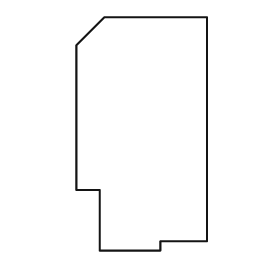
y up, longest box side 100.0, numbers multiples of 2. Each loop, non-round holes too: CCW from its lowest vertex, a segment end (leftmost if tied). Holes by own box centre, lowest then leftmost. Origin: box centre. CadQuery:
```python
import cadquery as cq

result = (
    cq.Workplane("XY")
    .moveTo(-18.0, -50.0)
    .lineTo(8.0, -50.0)
    .lineTo(8.0, -46.0)
    .lineTo(28.0, -46.0)
    .lineTo(28.0, 50.0)
    .lineTo(-16.0, 50.0)
    .lineTo(-28.0, 38.0)
    .lineTo(-28.0, -24.0)
    .lineTo(-18.0, -24.0)
    .close()
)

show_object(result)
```